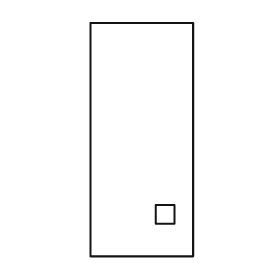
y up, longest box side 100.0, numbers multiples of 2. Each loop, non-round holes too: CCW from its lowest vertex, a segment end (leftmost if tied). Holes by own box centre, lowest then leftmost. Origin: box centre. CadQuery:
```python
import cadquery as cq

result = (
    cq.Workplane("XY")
    .moveTo(-22.0, -50.0)
    .lineTo(22.0, -50.0)
    .lineTo(22.0, 50.0)
    .lineTo(-22.0, 50.0)
    .close()
    .moveTo(6.0, -36.0)
    .lineTo(14.0, -36.0)
    .lineTo(14.0, -28.0)
    .lineTo(6.0, -28.0)
    .close()
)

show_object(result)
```